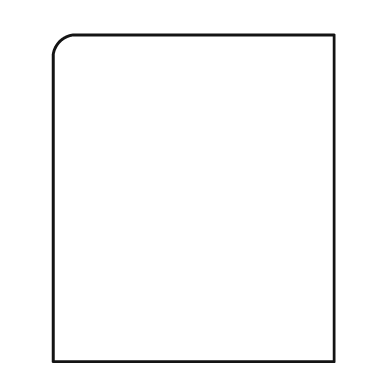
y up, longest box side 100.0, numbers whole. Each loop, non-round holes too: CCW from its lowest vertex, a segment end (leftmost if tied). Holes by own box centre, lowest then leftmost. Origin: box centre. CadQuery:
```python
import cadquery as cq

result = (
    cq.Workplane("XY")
    .moveTo(-43.0, -50.0)
    .lineTo(43.0, -50.0)
    .lineTo(43.0, 50.0)
    .lineTo(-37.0, 50.0)
    .threePointArc((-41.0, 48.0), (-43.0, 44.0))
    .close()
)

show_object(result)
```